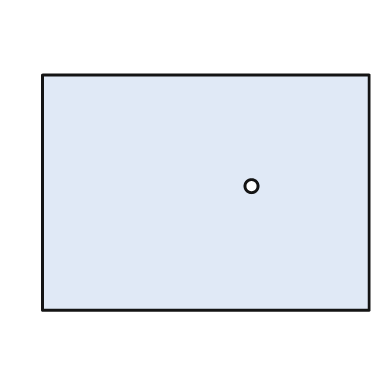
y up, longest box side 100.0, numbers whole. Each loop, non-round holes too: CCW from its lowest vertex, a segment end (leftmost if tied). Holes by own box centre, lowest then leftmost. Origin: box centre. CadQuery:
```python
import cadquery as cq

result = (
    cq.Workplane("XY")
    .moveTo(-50.0, -36.0)
    .lineTo(50.0, -36.0)
    .lineTo(50.0, 36.0)
    .lineTo(-50.0, 36.0)
    .close()
    .moveTo(14.0, 2.0)
    .circle(2.0)
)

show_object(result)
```